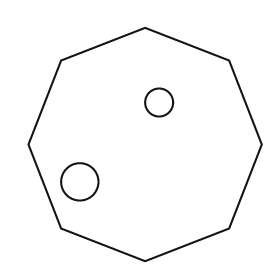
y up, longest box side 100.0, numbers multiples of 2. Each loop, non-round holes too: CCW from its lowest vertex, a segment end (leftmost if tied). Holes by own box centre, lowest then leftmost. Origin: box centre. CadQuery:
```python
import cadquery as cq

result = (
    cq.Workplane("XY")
    .moveTo(0.0, -50.0)
    .lineTo(36.0, -36.0)
    .lineTo(50.0, 0.0)
    .lineTo(36.0, 36.0)
    .lineTo(0.0, 50.0)
    .lineTo(-36.0, 36.0)
    .lineTo(-50.0, 0.0)
    .lineTo(-36.0, -36.0)
    .close()
    .moveTo(-28.0, -16.0)
    .circle(8.0)
    .moveTo(6.0, 18.0)
    .circle(6.0)
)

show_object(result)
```